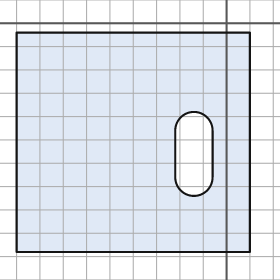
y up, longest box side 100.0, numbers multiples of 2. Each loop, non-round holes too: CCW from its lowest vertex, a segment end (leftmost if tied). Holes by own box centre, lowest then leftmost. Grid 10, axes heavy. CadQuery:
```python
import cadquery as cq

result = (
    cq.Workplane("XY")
    .moveTo(-90.0, -98.0)
    .lineTo(10.0, -98.0)
    .lineTo(10.0, -4.0)
    .lineTo(-90.0, -4.0)
    .close()
    .moveTo(-22.0, -66.0)
    .threePointArc((-14.0, -74.0), (-6.0, -66.0))
    .lineTo(-6.0, -46.0)
    .threePointArc((-14.0, -38.0), (-22.0, -46.0))
    .close()
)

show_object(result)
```